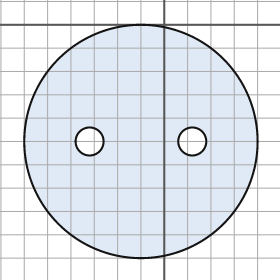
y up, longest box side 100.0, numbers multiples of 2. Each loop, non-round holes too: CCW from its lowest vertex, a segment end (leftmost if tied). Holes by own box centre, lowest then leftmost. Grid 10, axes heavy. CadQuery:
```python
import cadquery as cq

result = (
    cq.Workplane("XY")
    .moveTo(-10.0, -50.0)
    .circle(50.0)
    .moveTo(-32.0, -50.0)
    .circle(6.0)
    .moveTo(12.0, -50.0)
    .circle(6.0)
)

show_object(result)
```